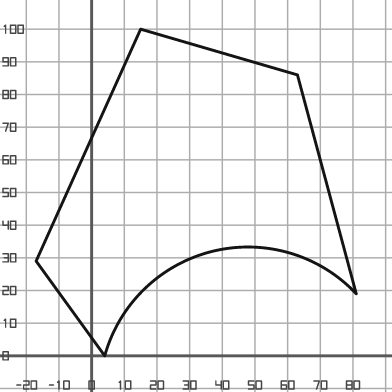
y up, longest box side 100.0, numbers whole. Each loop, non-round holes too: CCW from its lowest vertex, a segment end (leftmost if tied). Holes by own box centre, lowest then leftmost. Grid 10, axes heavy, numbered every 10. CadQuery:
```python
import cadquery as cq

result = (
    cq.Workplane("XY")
    .moveTo(4.0, 0.0)
    .threePointArc((37.0, 32.0), (81.0, 19.0))
    .lineTo(63.0, 86.0)
    .lineTo(15.0, 100.0)
    .lineTo(-17.0, 29.0)
    .close()
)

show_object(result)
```